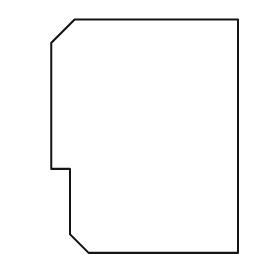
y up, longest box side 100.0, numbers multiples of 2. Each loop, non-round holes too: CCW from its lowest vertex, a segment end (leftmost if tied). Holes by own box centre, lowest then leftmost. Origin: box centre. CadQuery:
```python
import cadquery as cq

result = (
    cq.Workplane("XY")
    .moveTo(-24.0, -50.0)
    .lineTo(40.0, -50.0)
    .lineTo(40.0, 50.0)
    .lineTo(-30.0, 50.0)
    .lineTo(-40.0, 40.0)
    .lineTo(-40.0, -14.0)
    .lineTo(-32.0, -14.0)
    .lineTo(-32.0, -42.0)
    .close()
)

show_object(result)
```